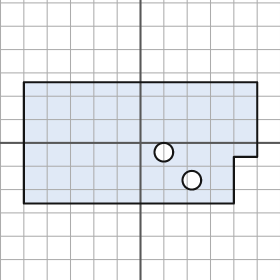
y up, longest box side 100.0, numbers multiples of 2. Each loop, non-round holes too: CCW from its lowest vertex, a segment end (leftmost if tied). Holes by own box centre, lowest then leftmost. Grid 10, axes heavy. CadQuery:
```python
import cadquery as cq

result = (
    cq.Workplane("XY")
    .moveTo(-50.0, -26.0)
    .lineTo(40.0, -26.0)
    .lineTo(40.0, -6.0)
    .lineTo(50.0, -6.0)
    .lineTo(50.0, 26.0)
    .lineTo(-50.0, 26.0)
    .close()
    .moveTo(22.0, -16.0)
    .circle(4.0)
    .moveTo(10.0, -4.0)
    .circle(4.0)
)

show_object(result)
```